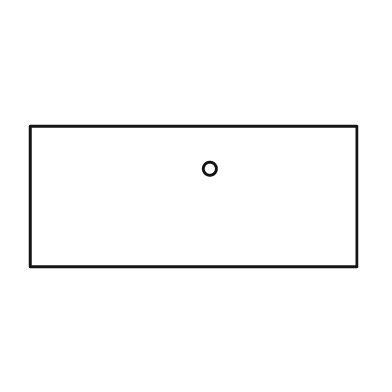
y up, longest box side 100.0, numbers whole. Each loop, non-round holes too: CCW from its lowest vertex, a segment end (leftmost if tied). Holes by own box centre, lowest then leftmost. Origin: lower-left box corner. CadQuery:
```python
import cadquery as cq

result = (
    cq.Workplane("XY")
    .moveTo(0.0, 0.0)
    .lineTo(100.0, 0.0)
    .lineTo(100.0, 43.0)
    .lineTo(0.0, 43.0)
    .close()
    .moveTo(55.0, 30.0)
    .circle(2.0)
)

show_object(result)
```